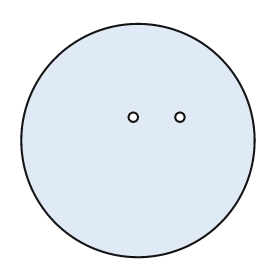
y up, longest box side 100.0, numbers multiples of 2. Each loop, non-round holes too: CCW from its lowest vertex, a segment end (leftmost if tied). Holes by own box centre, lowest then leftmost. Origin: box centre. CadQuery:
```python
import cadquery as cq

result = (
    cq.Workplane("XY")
    .moveTo(0.0, 0.0)
    .circle(50.0)
    .moveTo(-2.0, 10.0)
    .circle(2.0)
    .moveTo(18.0, 10.0)
    .circle(2.0)
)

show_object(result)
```